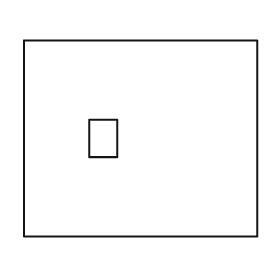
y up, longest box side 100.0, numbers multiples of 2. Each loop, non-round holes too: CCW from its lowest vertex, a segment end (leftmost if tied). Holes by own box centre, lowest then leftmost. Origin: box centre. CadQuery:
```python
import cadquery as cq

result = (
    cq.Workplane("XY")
    .moveTo(-50.0, -42.0)
    .lineTo(50.0, -42.0)
    .lineTo(50.0, 42.0)
    .lineTo(-50.0, 42.0)
    .close()
    .moveTo(-22.0, -8.0)
    .lineTo(-10.0, -8.0)
    .lineTo(-10.0, 8.0)
    .lineTo(-22.0, 8.0)
    .close()
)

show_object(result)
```